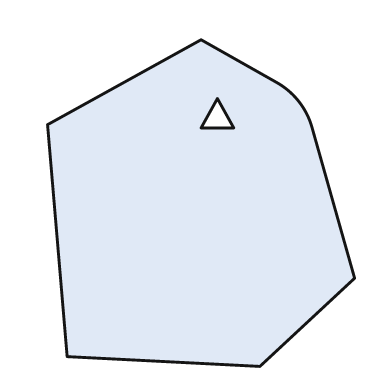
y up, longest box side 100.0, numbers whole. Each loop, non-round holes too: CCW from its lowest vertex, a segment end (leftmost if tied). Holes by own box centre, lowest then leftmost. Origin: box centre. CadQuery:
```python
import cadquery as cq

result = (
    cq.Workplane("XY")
    .moveTo(18.0, -50.0)
    .lineTo(47.0, -23.0)
    .lineTo(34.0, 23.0)
    .threePointArc((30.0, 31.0), (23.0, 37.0))
    .lineTo(0.0, 50.0)
    .lineTo(-47.0, 24.0)
    .lineTo(-41.0, -47.0)
    .close()
    .moveTo(0.0, 23.0)
    .lineTo(10.0, 23.0)
    .lineTo(5.0, 32.0)
    .close()
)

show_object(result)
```